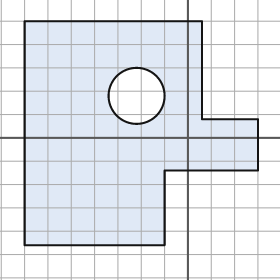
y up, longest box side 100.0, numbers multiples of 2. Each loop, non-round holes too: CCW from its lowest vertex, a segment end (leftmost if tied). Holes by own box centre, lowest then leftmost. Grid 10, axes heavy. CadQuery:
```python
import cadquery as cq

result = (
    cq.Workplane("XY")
    .moveTo(-70.0, -46.0)
    .lineTo(-10.0, -46.0)
    .lineTo(-10.0, -14.0)
    .lineTo(30.0, -14.0)
    .lineTo(30.0, 8.0)
    .lineTo(6.0, 8.0)
    .lineTo(6.0, 50.0)
    .lineTo(-70.0, 50.0)
    .close()
    .moveTo(-22.0, 18.0)
    .circle(12.0)
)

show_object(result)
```